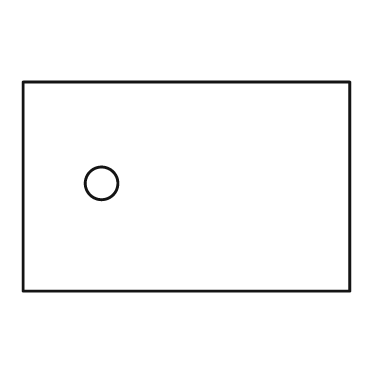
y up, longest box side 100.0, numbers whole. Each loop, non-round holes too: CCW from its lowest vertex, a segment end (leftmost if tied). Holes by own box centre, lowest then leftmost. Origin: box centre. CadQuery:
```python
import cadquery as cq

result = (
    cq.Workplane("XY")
    .moveTo(-50.0, -32.0)
    .lineTo(50.0, -32.0)
    .lineTo(50.0, 32.0)
    .lineTo(-50.0, 32.0)
    .close()
    .moveTo(-26.0, 1.0)
    .circle(5.0)
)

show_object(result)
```